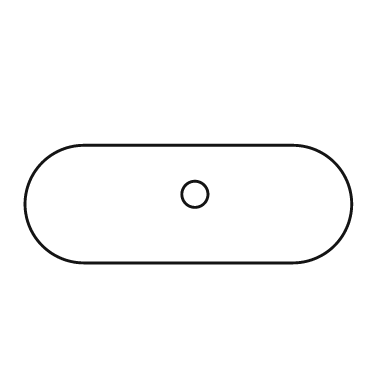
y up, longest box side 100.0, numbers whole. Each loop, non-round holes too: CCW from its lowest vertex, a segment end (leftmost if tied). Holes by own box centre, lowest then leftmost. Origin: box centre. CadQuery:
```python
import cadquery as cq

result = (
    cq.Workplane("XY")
    .moveTo(-32.0, -18.0)
    .lineTo(32.0, -18.0)
    .threePointArc((50.0, 0.0), (32.0, 18.0))
    .lineTo(-32.0, 18.0)
    .threePointArc((-50.0, 0.0), (-32.0, -18.0))
    .close()
    .moveTo(2.0, 3.0)
    .circle(4.0)
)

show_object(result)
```